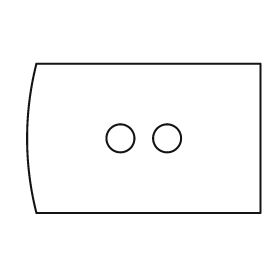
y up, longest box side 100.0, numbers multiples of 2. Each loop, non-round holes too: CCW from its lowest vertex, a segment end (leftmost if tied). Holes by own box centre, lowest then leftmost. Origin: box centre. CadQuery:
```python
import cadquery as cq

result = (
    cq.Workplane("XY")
    .moveTo(-46.0, -32.0)
    .lineTo(50.0, -32.0)
    .lineTo(50.0, 32.0)
    .lineTo(-46.0, 32.0)
    .threePointArc((-50.0, 0.0), (-46.0, -32.0))
    .close()
    .moveTo(-10.0, 0.0)
    .circle(6.0)
    .moveTo(10.0, 0.0)
    .circle(6.0)
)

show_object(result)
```